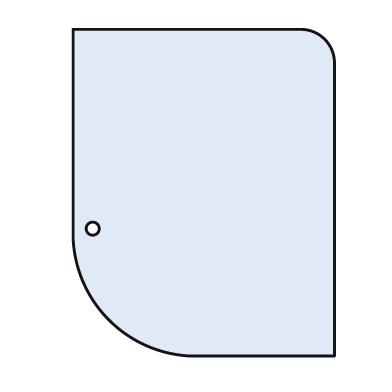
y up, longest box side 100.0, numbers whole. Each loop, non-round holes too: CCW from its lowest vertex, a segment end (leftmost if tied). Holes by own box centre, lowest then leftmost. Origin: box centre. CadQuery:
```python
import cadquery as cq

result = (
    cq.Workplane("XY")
    .moveTo(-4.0, -50.0)
    .lineTo(40.0, -50.0)
    .lineTo(40.0, 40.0)
    .threePointArc((37.0, 47.0), (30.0, 50.0))
    .lineTo(-40.0, 50.0)
    .lineTo(-40.0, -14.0)
    .threePointArc((-29.0, -39.0), (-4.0, -50.0))
    .close()
    .moveTo(-34.0, -11.0)
    .circle(2.0)
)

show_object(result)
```